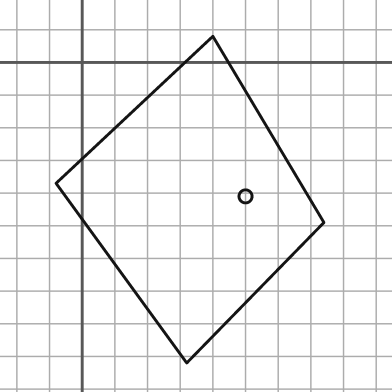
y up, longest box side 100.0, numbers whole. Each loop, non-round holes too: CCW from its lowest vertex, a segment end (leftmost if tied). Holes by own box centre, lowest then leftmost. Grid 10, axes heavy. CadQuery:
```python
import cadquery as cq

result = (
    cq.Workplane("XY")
    .moveTo(32.0, -92.0)
    .lineTo(74.0, -49.0)
    .lineTo(40.0, 8.0)
    .lineTo(-8.0, -37.0)
    .close()
    .moveTo(50.0, -41.0)
    .circle(2.0)
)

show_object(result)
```